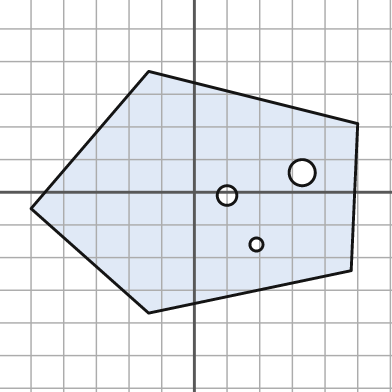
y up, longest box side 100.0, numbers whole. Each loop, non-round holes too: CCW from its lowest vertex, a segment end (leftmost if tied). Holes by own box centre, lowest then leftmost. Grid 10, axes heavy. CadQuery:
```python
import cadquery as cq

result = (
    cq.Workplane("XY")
    .moveTo(-14.0, -37.0)
    .lineTo(48.0, -24.0)
    .lineTo(50.0, 21.0)
    .lineTo(-14.0, 37.0)
    .lineTo(-50.0, -5.0)
    .close()
    .moveTo(19.0, -16.0)
    .circle(2.0)
    .moveTo(10.0, -1.0)
    .circle(3.0)
    .moveTo(33.0, 6.0)
    .circle(4.0)
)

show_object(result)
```